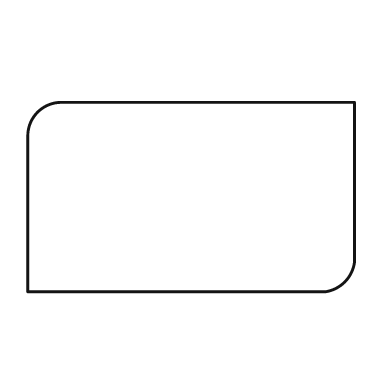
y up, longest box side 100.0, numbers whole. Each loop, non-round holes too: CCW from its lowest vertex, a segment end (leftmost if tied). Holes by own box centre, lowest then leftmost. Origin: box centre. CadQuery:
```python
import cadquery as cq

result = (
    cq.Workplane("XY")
    .moveTo(-50.0, -29.0)
    .lineTo(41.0, -29.0)
    .threePointArc((47.0, -26.0), (50.0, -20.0))
    .lineTo(50.0, 29.0)
    .lineTo(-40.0, 29.0)
    .threePointArc((-47.0, 26.0), (-50.0, 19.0))
    .close()
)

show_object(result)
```